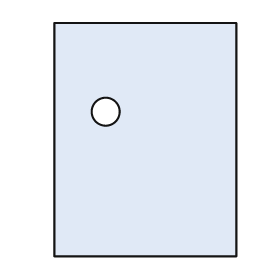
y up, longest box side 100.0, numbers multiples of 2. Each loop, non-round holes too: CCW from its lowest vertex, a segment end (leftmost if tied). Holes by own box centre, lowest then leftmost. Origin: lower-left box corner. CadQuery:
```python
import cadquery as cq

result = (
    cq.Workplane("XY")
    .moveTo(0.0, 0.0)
    .lineTo(78.0, 0.0)
    .lineTo(78.0, 100.0)
    .lineTo(0.0, 100.0)
    .close()
    .moveTo(22.0, 62.0)
    .circle(6.0)
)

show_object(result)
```